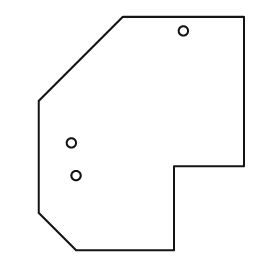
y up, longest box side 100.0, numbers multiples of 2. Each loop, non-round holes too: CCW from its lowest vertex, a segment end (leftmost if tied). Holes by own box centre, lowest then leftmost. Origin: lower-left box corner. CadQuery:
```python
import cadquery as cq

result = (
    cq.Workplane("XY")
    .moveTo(16.0, 0.0)
    .lineTo(58.0, 0.0)
    .lineTo(58.0, 36.0)
    .lineTo(88.0, 36.0)
    .lineTo(88.0, 100.0)
    .lineTo(36.0, 100.0)
    .lineTo(0.0, 64.0)
    .lineTo(0.0, 16.0)
    .close()
    .moveTo(16.0, 32.0)
    .circle(2.0)
    .moveTo(14.0, 46.0)
    .circle(2.0)
    .moveTo(62.0, 94.0)
    .circle(2.0)
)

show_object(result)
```